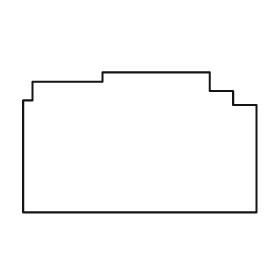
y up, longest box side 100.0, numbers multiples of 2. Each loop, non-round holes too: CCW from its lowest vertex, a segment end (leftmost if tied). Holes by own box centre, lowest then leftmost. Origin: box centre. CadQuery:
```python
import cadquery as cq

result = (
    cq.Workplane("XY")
    .moveTo(-50.0, -30.0)
    .lineTo(50.0, -30.0)
    .lineTo(50.0, 16.0)
    .lineTo(40.0, 16.0)
    .lineTo(40.0, 22.0)
    .lineTo(30.0, 22.0)
    .lineTo(30.0, 30.0)
    .lineTo(-16.0, 30.0)
    .lineTo(-16.0, 26.0)
    .lineTo(-46.0, 26.0)
    .lineTo(-46.0, 18.0)
    .lineTo(-50.0, 18.0)
    .close()
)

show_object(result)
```